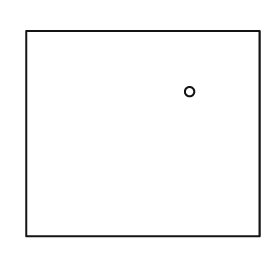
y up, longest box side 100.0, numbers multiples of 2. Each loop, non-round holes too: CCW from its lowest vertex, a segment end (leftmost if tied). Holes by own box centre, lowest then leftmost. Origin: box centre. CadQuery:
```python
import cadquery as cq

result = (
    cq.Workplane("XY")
    .moveTo(-50.0, -44.0)
    .lineTo(50.0, -44.0)
    .lineTo(50.0, 44.0)
    .lineTo(-50.0, 44.0)
    .close()
    .moveTo(20.0, 18.0)
    .circle(2.0)
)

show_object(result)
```